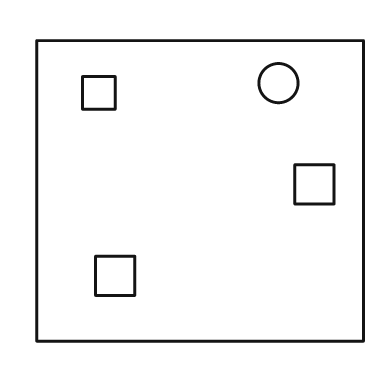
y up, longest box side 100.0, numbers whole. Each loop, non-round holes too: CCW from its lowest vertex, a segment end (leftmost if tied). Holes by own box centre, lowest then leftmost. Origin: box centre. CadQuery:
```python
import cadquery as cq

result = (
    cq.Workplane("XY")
    .moveTo(-50.0, -46.0)
    .lineTo(50.0, -46.0)
    .lineTo(50.0, 46.0)
    .lineTo(-50.0, 46.0)
    .close()
    .moveTo(-32.0, -32.0)
    .lineTo(-20.0, -32.0)
    .lineTo(-20.0, -20.0)
    .lineTo(-32.0, -20.0)
    .close()
    .moveTo(29.0, -4.0)
    .lineTo(41.0, -4.0)
    .lineTo(41.0, 8.0)
    .lineTo(29.0, 8.0)
    .close()
    .moveTo(-36.0, 25.0)
    .lineTo(-26.0, 25.0)
    .lineTo(-26.0, 35.0)
    .lineTo(-36.0, 35.0)
    .close()
    .moveTo(24.0, 33.0)
    .circle(6.0)
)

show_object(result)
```